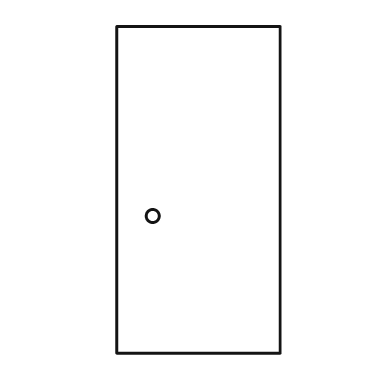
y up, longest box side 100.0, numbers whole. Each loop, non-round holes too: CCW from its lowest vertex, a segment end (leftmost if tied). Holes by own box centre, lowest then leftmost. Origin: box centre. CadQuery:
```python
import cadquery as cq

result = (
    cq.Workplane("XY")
    .moveTo(-25.0, -50.0)
    .lineTo(25.0, -50.0)
    .lineTo(25.0, 50.0)
    .lineTo(-25.0, 50.0)
    .close()
    .moveTo(-14.0, -8.0)
    .circle(2.0)
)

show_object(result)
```